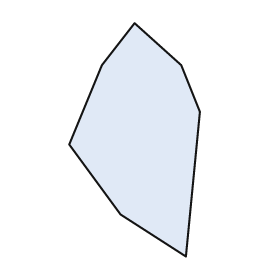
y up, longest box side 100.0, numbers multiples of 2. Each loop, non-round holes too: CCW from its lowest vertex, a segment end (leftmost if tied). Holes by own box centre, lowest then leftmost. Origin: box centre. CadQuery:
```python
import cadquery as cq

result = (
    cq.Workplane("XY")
    .moveTo(22.0, -50.0)
    .lineTo(28.0, 12.0)
    .lineTo(20.0, 32.0)
    .lineTo(0.0, 50.0)
    .lineTo(-14.0, 32.0)
    .lineTo(-28.0, -2.0)
    .lineTo(-6.0, -32.0)
    .close()
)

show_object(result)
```